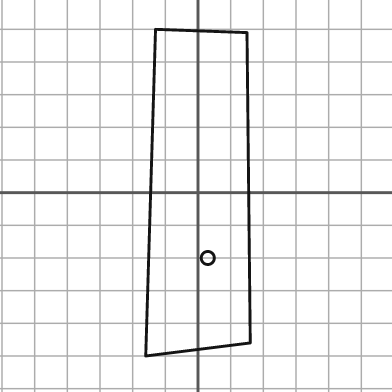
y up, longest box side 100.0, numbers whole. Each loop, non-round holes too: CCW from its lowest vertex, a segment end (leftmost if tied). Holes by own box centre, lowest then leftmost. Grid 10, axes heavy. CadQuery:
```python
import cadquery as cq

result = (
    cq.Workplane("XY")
    .moveTo(-16.0, -50.0)
    .lineTo(16.0, -46.0)
    .lineTo(15.0, 49.0)
    .lineTo(-13.0, 50.0)
    .close()
    .moveTo(3.0, -20.0)
    .circle(2.0)
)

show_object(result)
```